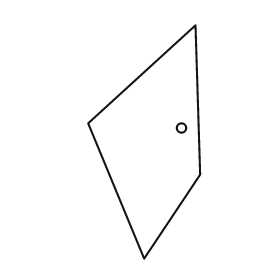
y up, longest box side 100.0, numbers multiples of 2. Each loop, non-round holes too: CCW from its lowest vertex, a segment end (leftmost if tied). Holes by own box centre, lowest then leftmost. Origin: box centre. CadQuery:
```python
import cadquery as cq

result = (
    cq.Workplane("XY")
    .moveTo(0.0, -50.0)
    .lineTo(24.0, -14.0)
    .lineTo(22.0, 50.0)
    .lineTo(-24.0, 8.0)
    .close()
    .moveTo(16.0, 6.0)
    .circle(2.0)
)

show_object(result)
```